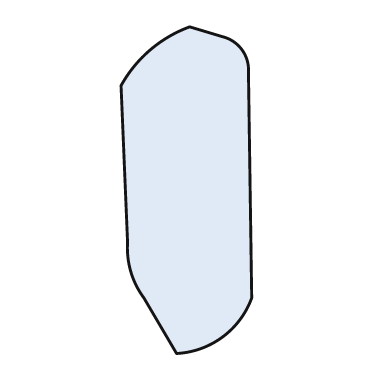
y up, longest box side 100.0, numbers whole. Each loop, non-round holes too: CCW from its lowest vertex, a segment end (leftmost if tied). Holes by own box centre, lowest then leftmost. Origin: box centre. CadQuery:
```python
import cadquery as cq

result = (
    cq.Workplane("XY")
    .moveTo(-3.0, -50.0)
    .threePointArc((11.0, -45.0), (20.0, -33.0))
    .lineTo(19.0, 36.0)
    .threePointArc((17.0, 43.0), (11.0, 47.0))
    .lineTo(1.0, 50.0)
    .threePointArc((-11.0, 43.0), (-20.0, 32.0))
    .lineTo(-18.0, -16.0)
    .threePointArc((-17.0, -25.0), (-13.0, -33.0))
    .close()
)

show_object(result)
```